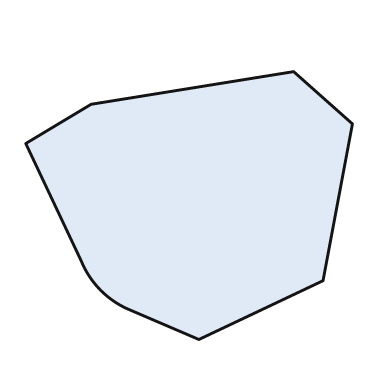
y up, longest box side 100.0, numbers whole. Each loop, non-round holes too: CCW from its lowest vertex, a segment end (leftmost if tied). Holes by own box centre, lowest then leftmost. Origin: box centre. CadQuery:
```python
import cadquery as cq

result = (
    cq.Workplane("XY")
    .moveTo(3.0, -41.0)
    .lineTo(41.0, -23.0)
    .lineTo(50.0, 25.0)
    .lineTo(32.0, 41.0)
    .lineTo(-30.0, 31.0)
    .lineTo(-50.0, 19.0)
    .lineTo(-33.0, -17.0)
    .threePointArc((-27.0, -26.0), (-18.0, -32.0))
    .close()
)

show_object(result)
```